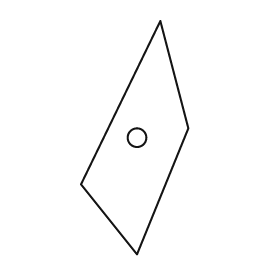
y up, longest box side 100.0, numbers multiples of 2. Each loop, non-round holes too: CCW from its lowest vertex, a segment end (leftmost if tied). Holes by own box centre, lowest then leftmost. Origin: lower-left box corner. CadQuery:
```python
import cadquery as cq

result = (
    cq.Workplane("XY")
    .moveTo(24.0, 0.0)
    .lineTo(46.0, 54.0)
    .lineTo(34.0, 100.0)
    .lineTo(0.0, 30.0)
    .close()
    .moveTo(24.0, 50.0)
    .circle(4.0)
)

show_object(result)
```